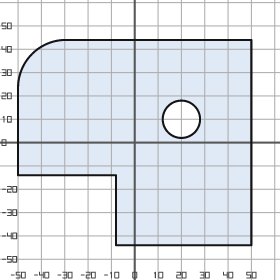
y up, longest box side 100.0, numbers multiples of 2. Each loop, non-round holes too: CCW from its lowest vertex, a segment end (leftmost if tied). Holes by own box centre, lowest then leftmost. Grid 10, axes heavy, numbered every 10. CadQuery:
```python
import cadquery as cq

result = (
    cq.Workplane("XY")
    .moveTo(-8.0, -44.0)
    .lineTo(50.0, -44.0)
    .lineTo(50.0, 44.0)
    .lineTo(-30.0, 44.0)
    .threePointArc((-44.0, 38.0), (-50.0, 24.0))
    .lineTo(-50.0, -14.0)
    .lineTo(-8.0, -14.0)
    .close()
    .moveTo(20.0, 10.0)
    .circle(8.0)
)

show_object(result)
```